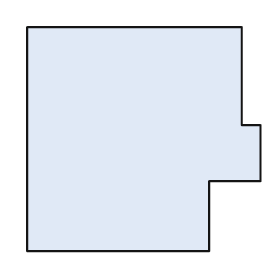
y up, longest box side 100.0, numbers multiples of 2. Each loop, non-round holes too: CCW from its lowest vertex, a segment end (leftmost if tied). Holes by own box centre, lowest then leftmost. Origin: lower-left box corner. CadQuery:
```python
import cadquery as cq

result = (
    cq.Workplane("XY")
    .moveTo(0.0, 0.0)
    .lineTo(78.0, 0.0)
    .lineTo(78.0, 30.0)
    .lineTo(100.0, 30.0)
    .lineTo(100.0, 54.0)
    .lineTo(92.0, 54.0)
    .lineTo(92.0, 96.0)
    .lineTo(0.0, 96.0)
    .close()
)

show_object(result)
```